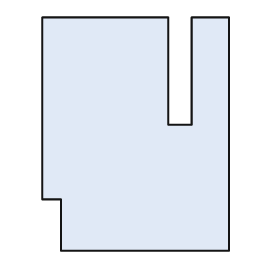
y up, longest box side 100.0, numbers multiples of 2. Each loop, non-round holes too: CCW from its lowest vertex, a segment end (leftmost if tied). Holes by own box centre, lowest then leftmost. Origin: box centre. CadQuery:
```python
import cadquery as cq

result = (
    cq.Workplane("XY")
    .moveTo(-32.0, -50.0)
    .lineTo(40.0, -50.0)
    .lineTo(40.0, 50.0)
    .lineTo(24.0, 50.0)
    .lineTo(24.0, 4.0)
    .lineTo(14.0, 4.0)
    .lineTo(14.0, 50.0)
    .lineTo(-40.0, 50.0)
    .lineTo(-40.0, -28.0)
    .lineTo(-32.0, -28.0)
    .close()
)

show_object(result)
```